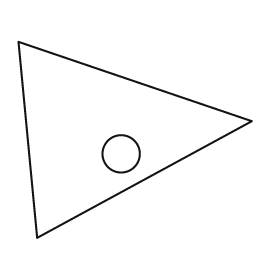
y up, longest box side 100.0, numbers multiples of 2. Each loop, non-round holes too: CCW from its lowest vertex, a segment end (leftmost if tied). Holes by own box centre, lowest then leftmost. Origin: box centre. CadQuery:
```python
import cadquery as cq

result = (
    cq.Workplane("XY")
    .moveTo(-42.0, -42.0)
    .lineTo(50.0, 8.0)
    .lineTo(-50.0, 42.0)
    .close()
    .moveTo(-6.0, -6.0)
    .circle(8.0)
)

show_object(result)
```